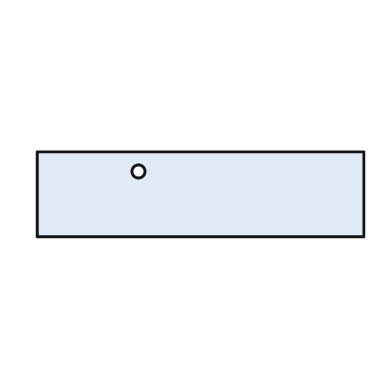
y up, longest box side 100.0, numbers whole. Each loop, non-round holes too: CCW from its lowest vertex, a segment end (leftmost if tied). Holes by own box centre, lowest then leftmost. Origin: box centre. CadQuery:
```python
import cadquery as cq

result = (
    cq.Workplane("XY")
    .moveTo(-50.0, -13.0)
    .lineTo(50.0, -13.0)
    .lineTo(50.0, 13.0)
    .lineTo(-50.0, 13.0)
    .close()
    .moveTo(-19.0, 7.0)
    .circle(2.0)
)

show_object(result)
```